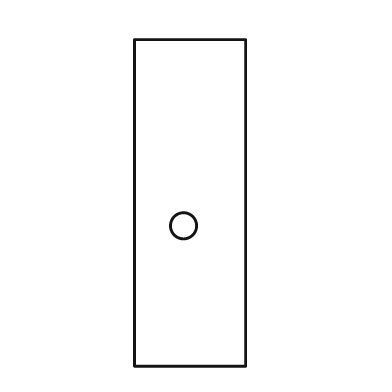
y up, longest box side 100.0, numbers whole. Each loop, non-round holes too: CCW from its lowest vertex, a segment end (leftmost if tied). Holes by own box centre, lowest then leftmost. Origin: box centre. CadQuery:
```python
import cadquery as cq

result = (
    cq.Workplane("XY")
    .moveTo(-17.0, -50.0)
    .lineTo(17.0, -50.0)
    .lineTo(17.0, 50.0)
    .lineTo(-17.0, 50.0)
    .close()
    .moveTo(-2.0, -7.0)
    .circle(4.0)
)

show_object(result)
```